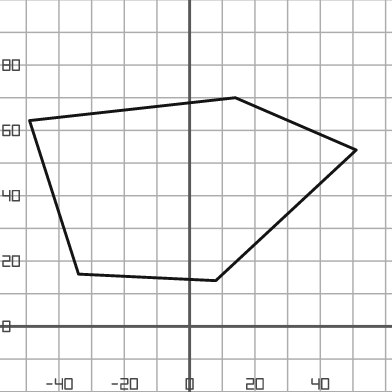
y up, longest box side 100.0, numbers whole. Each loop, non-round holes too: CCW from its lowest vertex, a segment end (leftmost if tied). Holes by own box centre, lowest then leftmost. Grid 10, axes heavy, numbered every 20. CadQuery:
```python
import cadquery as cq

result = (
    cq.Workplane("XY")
    .moveTo(8.0, 14.0)
    .lineTo(51.0, 54.0)
    .lineTo(14.0, 70.0)
    .lineTo(-49.0, 63.0)
    .lineTo(-34.0, 16.0)
    .close()
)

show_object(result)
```